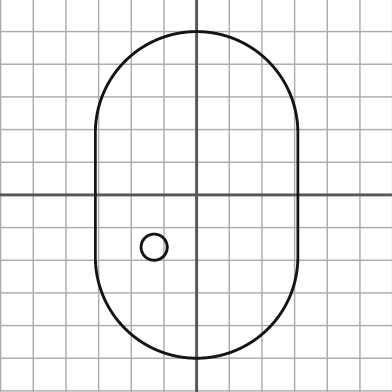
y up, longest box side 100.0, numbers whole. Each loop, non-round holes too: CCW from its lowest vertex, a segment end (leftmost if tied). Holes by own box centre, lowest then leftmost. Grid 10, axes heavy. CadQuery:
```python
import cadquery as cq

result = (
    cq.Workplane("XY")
    .moveTo(-31.0, -19.0)
    .threePointArc((0.0, -50.0), (31.0, -19.0))
    .lineTo(31.0, 19.0)
    .threePointArc((0.0, 50.0), (-31.0, 19.0))
    .close()
    .moveTo(-13.0, -16.0)
    .circle(4.0)
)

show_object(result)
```